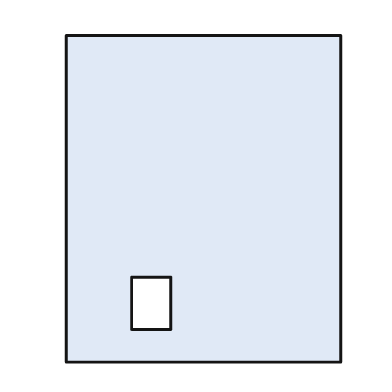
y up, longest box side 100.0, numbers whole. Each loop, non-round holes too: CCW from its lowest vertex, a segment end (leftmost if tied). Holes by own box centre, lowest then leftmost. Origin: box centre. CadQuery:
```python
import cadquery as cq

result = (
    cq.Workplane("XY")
    .moveTo(-42.0, -50.0)
    .lineTo(42.0, -50.0)
    .lineTo(42.0, 50.0)
    .lineTo(-42.0, 50.0)
    .close()
    .moveTo(-22.0, -40.0)
    .lineTo(-10.0, -40.0)
    .lineTo(-10.0, -24.0)
    .lineTo(-22.0, -24.0)
    .close()
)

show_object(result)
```